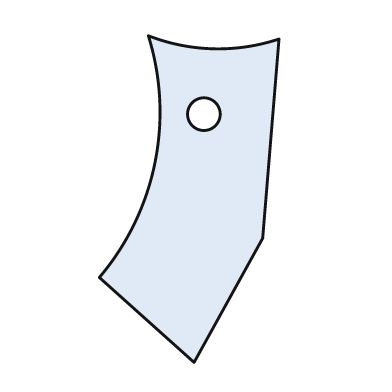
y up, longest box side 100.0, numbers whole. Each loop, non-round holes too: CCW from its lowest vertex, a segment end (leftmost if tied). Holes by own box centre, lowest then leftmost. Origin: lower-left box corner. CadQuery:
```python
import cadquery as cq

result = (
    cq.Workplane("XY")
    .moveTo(29.0, 0.0)
    .lineTo(50.0, 38.0)
    .lineTo(55.0, 99.0)
    .threePointArc((35.0, 96.0), (15.0, 100.0))
    .threePointArc((17.0, 61.0), (0.0, 26.0))
    .close()
    .moveTo(32.0, 76.0)
    .circle(5.0)
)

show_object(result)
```